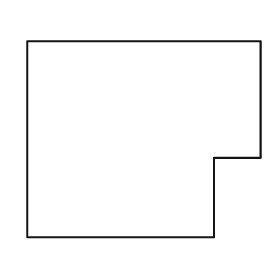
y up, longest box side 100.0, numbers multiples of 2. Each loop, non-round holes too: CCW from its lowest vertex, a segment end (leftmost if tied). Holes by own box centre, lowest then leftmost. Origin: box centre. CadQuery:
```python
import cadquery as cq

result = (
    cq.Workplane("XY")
    .moveTo(-50.0, -42.0)
    .lineTo(30.0, -42.0)
    .lineTo(30.0, -8.0)
    .lineTo(50.0, -8.0)
    .lineTo(50.0, 42.0)
    .lineTo(-50.0, 42.0)
    .close()
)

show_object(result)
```